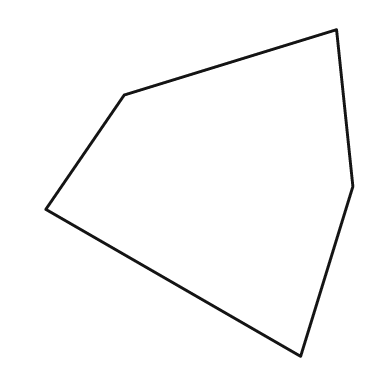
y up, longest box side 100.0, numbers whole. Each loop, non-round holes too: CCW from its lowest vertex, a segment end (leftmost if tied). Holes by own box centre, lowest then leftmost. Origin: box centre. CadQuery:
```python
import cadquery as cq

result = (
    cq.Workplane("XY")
    .moveTo(31.0, -50.0)
    .lineTo(47.0, 2.0)
    .lineTo(42.0, 50.0)
    .lineTo(-23.0, 30.0)
    .lineTo(-47.0, -5.0)
    .close()
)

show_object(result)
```